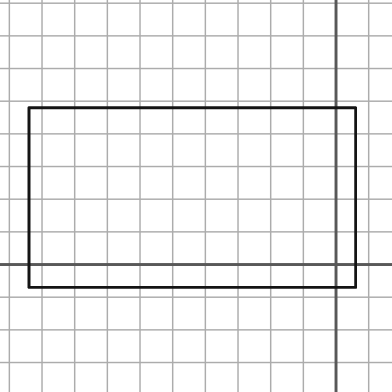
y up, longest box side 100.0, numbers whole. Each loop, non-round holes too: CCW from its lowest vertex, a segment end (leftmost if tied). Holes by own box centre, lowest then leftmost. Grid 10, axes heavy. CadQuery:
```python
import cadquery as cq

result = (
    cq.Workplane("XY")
    .moveTo(-94.0, -7.0)
    .lineTo(6.0, -7.0)
    .lineTo(6.0, 48.0)
    .lineTo(-94.0, 48.0)
    .close()
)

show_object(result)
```